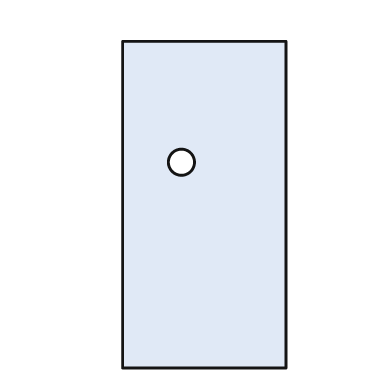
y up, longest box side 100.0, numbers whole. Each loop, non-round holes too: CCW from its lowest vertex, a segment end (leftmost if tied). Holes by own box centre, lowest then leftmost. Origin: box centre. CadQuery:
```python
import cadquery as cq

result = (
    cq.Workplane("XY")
    .moveTo(-25.0, -50.0)
    .lineTo(25.0, -50.0)
    .lineTo(25.0, 50.0)
    .lineTo(-25.0, 50.0)
    .close()
    .moveTo(-7.0, 13.0)
    .circle(4.0)
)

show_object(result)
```